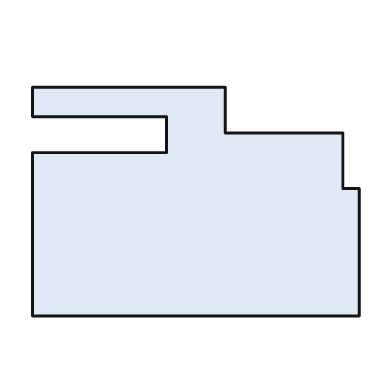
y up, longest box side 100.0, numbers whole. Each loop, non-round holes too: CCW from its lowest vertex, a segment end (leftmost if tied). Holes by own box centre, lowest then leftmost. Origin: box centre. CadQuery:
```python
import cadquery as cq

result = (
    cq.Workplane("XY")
    .moveTo(-50.0, -35.0)
    .lineTo(50.0, -35.0)
    .lineTo(50.0, 4.0)
    .lineTo(45.0, 4.0)
    .lineTo(45.0, 21.0)
    .lineTo(9.0, 21.0)
    .lineTo(9.0, 35.0)
    .lineTo(-50.0, 35.0)
    .lineTo(-50.0, 26.0)
    .lineTo(-9.0, 26.0)
    .lineTo(-9.0, 15.0)
    .lineTo(-50.0, 15.0)
    .close()
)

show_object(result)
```